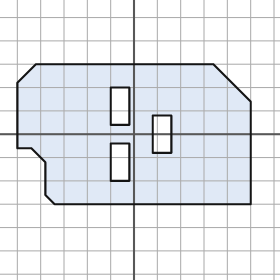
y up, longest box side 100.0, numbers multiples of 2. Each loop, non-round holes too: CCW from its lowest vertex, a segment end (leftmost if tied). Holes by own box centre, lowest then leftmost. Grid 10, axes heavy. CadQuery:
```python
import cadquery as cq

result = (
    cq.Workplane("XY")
    .moveTo(-34.0, -30.0)
    .lineTo(50.0, -30.0)
    .lineTo(50.0, 14.0)
    .lineTo(34.0, 30.0)
    .lineTo(-42.0, 30.0)
    .lineTo(-50.0, 22.0)
    .lineTo(-50.0, -6.0)
    .lineTo(-44.0, -6.0)
    .lineTo(-38.0, -12.0)
    .lineTo(-38.0, -26.0)
    .close()
    .moveTo(-10.0, -20.0)
    .lineTo(-2.0, -20.0)
    .lineTo(-2.0, -4.0)
    .lineTo(-10.0, -4.0)
    .close()
    .moveTo(8.0, -8.0)
    .lineTo(16.0, -8.0)
    .lineTo(16.0, 8.0)
    .lineTo(8.0, 8.0)
    .close()
    .moveTo(-10.0, 4.0)
    .lineTo(-2.0, 4.0)
    .lineTo(-2.0, 20.0)
    .lineTo(-10.0, 20.0)
    .close()
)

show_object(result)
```